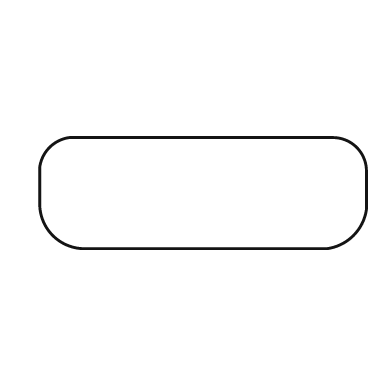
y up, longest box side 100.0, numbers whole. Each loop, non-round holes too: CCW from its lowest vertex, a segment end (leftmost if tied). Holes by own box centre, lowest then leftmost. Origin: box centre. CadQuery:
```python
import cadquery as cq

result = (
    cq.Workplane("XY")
    .moveTo(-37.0, -17.0)
    .lineTo(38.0, -17.0)
    .threePointArc((46.0, -13.0), (50.0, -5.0))
    .lineTo(50.0, 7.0)
    .threePointArc((47.0, 14.0), (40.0, 17.0))
    .lineTo(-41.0, 17.0)
    .threePointArc((-47.0, 14.0), (-50.0, 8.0))
    .lineTo(-50.0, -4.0)
    .threePointArc((-46.0, -13.0), (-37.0, -17.0))
    .close()
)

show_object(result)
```